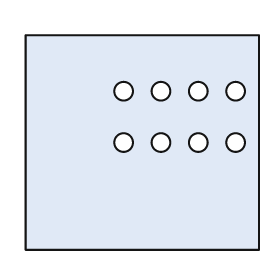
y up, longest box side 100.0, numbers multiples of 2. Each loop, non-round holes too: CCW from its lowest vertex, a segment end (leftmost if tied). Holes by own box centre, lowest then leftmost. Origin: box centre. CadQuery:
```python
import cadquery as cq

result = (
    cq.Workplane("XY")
    .moveTo(-50.0, -46.0)
    .lineTo(50.0, -46.0)
    .lineTo(50.0, 46.0)
    .lineTo(-50.0, 46.0)
    .close()
    .moveTo(-8.0, 0.0)
    .circle(4.0)
    .moveTo(8.0, 0.0)
    .circle(4.0)
    .moveTo(24.0, 0.0)
    .circle(4.0)
    .moveTo(40.0, 0.0)
    .circle(4.0)
    .moveTo(-8.0, 22.0)
    .circle(4.0)
    .moveTo(8.0, 22.0)
    .circle(4.0)
    .moveTo(24.0, 22.0)
    .circle(4.0)
    .moveTo(40.0, 22.0)
    .circle(4.0)
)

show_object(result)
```